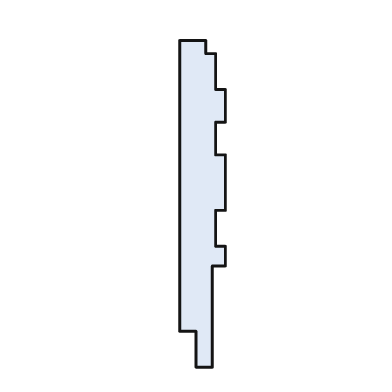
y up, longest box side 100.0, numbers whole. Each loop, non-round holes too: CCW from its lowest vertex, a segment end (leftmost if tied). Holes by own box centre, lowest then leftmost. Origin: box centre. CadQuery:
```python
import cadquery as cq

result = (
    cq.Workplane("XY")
    .moveTo(-2.0, -50.0)
    .lineTo(3.0, -50.0)
    .lineTo(3.0, -19.0)
    .lineTo(7.0, -19.0)
    .lineTo(7.0, -13.0)
    .lineTo(4.0, -13.0)
    .lineTo(4.0, -2.0)
    .lineTo(7.0, -2.0)
    .lineTo(7.0, 15.0)
    .lineTo(4.0, 15.0)
    .lineTo(4.0, 25.0)
    .lineTo(7.0, 25.0)
    .lineTo(7.0, 35.0)
    .lineTo(4.0, 35.0)
    .lineTo(4.0, 46.0)
    .lineTo(1.0, 46.0)
    .lineTo(1.0, 50.0)
    .lineTo(-7.0, 50.0)
    .lineTo(-7.0, -39.0)
    .lineTo(-2.0, -39.0)
    .close()
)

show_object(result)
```